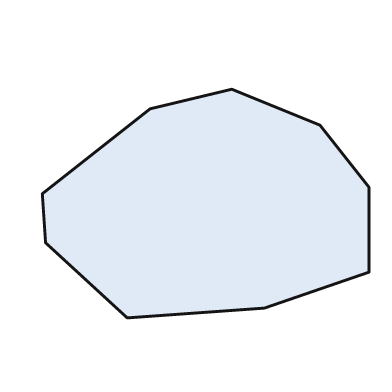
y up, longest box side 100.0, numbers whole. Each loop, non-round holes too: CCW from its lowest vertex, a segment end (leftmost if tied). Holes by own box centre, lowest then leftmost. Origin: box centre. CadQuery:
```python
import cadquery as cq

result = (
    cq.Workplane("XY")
    .moveTo(-24.0, -35.0)
    .lineTo(18.0, -32.0)
    .lineTo(50.0, -21.0)
    .lineTo(50.0, 5.0)
    .lineTo(35.0, 24.0)
    .lineTo(8.0, 35.0)
    .lineTo(-17.0, 29.0)
    .lineTo(-50.0, 3.0)
    .lineTo(-49.0, -12.0)
    .close()
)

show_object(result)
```